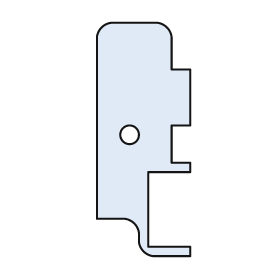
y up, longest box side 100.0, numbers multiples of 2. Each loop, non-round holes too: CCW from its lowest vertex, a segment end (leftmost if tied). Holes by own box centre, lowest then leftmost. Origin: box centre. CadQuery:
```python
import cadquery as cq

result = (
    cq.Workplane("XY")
    .moveTo(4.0, -50.0)
    .lineTo(20.0, -50.0)
    .lineTo(20.0, -46.0)
    .lineTo(2.0, -46.0)
    .lineTo(2.0, -14.0)
    .lineTo(20.0, -14.0)
    .lineTo(20.0, -10.0)
    .lineTo(12.0, -10.0)
    .lineTo(12.0, 6.0)
    .lineTo(20.0, 6.0)
    .lineTo(20.0, 30.0)
    .lineTo(12.0, 30.0)
    .lineTo(12.0, 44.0)
    .threePointArc((10.0, 48.0), (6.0, 50.0))
    .lineTo(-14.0, 50.0)
    .threePointArc((-18.0, 48.0), (-20.0, 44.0))
    .lineTo(-20.0, -34.0)
    .lineTo(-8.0, -34.0)
    .threePointArc((-4.0, -36.0), (-2.0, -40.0))
    .lineTo(-2.0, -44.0)
    .threePointArc((0.0, -48.0), (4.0, -50.0))
    .close()
    .moveTo(-6.0, 2.0)
    .circle(4.0)
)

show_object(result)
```